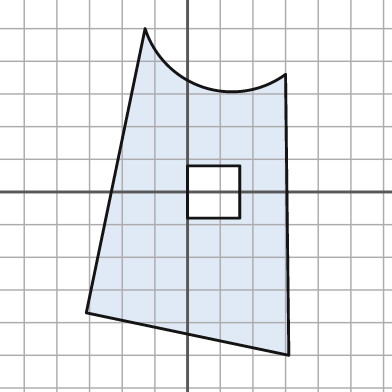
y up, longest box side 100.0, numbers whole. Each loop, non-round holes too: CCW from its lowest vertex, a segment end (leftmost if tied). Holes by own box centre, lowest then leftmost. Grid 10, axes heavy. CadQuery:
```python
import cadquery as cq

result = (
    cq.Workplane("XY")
    .moveTo(31.0, -50.0)
    .lineTo(30.0, 36.0)
    .threePointArc((5.0, 32.0), (-13.0, 50.0))
    .lineTo(-31.0, -37.0)
    .close()
    .moveTo(0.0, -8.0)
    .lineTo(16.0, -8.0)
    .lineTo(16.0, 8.0)
    .lineTo(0.0, 8.0)
    .close()
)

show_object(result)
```